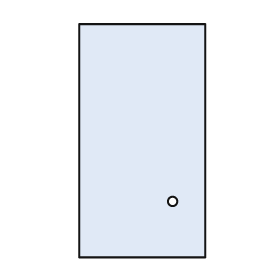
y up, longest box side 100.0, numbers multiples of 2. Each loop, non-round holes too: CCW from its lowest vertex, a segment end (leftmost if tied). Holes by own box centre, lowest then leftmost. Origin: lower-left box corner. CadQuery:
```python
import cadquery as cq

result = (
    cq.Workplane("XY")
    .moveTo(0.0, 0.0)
    .lineTo(54.0, 0.0)
    .lineTo(54.0, 100.0)
    .lineTo(0.0, 100.0)
    .close()
    .moveTo(40.0, 24.0)
    .circle(2.0)
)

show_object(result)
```